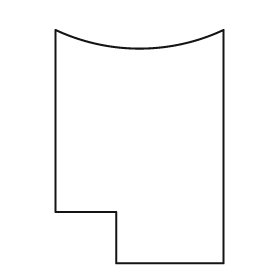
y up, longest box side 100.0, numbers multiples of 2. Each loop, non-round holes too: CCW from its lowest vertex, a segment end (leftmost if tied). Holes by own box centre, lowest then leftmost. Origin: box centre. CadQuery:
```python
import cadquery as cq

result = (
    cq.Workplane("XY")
    .moveTo(-10.0, -50.0)
    .lineTo(36.0, -50.0)
    .lineTo(36.0, 50.0)
    .threePointArc((0.0, 42.0), (-36.0, 50.0))
    .lineTo(-36.0, -28.0)
    .lineTo(-10.0, -28.0)
    .close()
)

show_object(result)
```